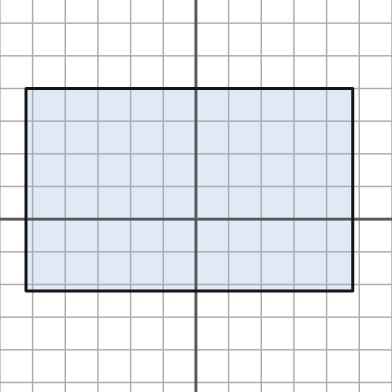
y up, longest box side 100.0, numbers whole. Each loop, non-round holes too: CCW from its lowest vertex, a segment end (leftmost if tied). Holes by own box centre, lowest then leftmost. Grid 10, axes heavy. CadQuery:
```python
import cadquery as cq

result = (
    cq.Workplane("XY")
    .moveTo(-52.0, -22.0)
    .lineTo(48.0, -22.0)
    .lineTo(48.0, 40.0)
    .lineTo(-52.0, 40.0)
    .close()
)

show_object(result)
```